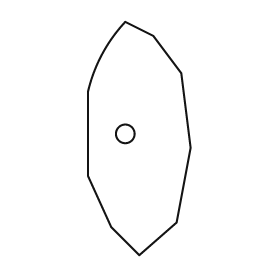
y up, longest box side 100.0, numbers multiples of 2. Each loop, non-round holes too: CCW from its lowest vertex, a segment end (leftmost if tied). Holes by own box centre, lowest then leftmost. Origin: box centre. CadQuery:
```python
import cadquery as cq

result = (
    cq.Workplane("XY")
    .moveTo(0.0, -50.0)
    .lineTo(16.0, -36.0)
    .lineTo(22.0, -4.0)
    .lineTo(18.0, 28.0)
    .lineTo(6.0, 44.0)
    .lineTo(-6.0, 50.0)
    .threePointArc((-16.0, 36.0), (-22.0, 20.0))
    .lineTo(-22.0, -16.0)
    .lineTo(-12.0, -38.0)
    .close()
    .moveTo(-6.0, 2.0)
    .circle(4.0)
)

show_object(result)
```